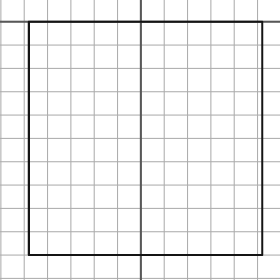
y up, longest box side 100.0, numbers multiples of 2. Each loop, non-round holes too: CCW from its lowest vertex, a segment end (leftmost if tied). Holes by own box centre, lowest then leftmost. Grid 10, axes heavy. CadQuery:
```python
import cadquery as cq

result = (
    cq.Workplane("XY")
    .moveTo(-48.0, -100.0)
    .lineTo(52.0, -100.0)
    .lineTo(52.0, 0.0)
    .lineTo(-48.0, 0.0)
    .close()
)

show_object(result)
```